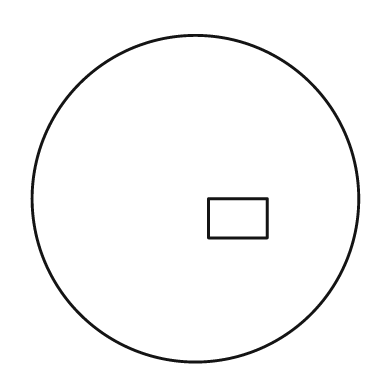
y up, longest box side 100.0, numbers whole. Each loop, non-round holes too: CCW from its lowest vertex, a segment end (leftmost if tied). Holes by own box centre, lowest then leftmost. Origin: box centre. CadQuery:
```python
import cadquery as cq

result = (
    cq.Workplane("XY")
    .moveTo(0.0, 0.0)
    .circle(50.0)
    .moveTo(4.0, -12.0)
    .lineTo(22.0, -12.0)
    .lineTo(22.0, 0.0)
    .lineTo(4.0, 0.0)
    .close()
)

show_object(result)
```